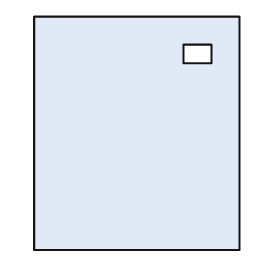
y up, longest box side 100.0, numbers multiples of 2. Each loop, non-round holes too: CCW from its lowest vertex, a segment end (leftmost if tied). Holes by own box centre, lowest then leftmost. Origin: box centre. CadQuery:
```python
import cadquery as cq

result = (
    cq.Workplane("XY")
    .moveTo(-44.0, -50.0)
    .lineTo(44.0, -50.0)
    .lineTo(44.0, 50.0)
    .lineTo(-44.0, 50.0)
    .close()
    .moveTo(20.0, 30.0)
    .lineTo(32.0, 30.0)
    .lineTo(32.0, 38.0)
    .lineTo(20.0, 38.0)
    .close()
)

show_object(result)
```